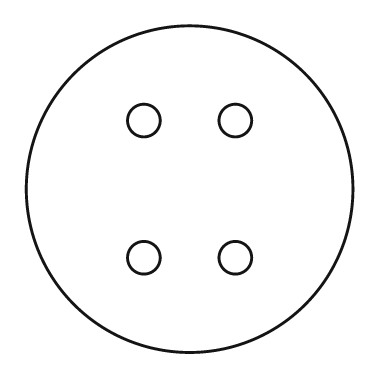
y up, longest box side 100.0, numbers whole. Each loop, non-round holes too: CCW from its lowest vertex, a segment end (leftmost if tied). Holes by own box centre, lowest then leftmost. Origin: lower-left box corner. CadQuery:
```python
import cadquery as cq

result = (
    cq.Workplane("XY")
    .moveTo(50.0, 50.0)
    .circle(50.0)
    .moveTo(36.0, 29.0)
    .circle(5.0)
    .moveTo(64.0, 29.0)
    .circle(5.0)
    .moveTo(36.0, 71.0)
    .circle(5.0)
    .moveTo(64.0, 71.0)
    .circle(5.0)
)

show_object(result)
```